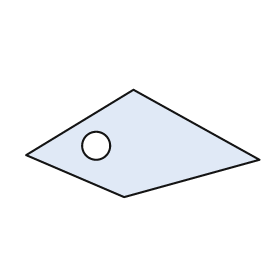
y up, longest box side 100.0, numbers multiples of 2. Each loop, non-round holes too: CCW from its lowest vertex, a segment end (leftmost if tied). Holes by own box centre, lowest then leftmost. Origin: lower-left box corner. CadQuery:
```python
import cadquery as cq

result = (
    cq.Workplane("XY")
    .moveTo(42.0, 0.0)
    .lineTo(100.0, 16.0)
    .lineTo(46.0, 46.0)
    .lineTo(0.0, 18.0)
    .close()
    .moveTo(30.0, 22.0)
    .circle(6.0)
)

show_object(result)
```